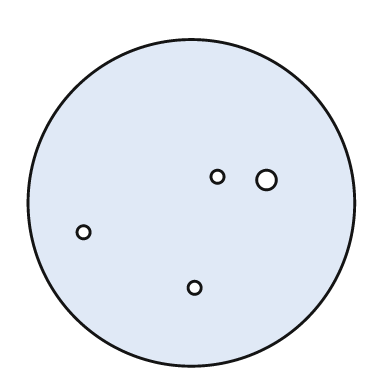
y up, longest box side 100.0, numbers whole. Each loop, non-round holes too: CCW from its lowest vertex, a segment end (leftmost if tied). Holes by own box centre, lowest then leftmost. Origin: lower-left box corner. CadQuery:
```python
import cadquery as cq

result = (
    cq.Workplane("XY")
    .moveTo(50.0, 50.0)
    .circle(50.0)
    .moveTo(51.0, 24.0)
    .circle(2.0)
    .moveTo(17.0, 41.0)
    .circle(2.0)
    .moveTo(73.0, 57.0)
    .circle(3.0)
    .moveTo(58.0, 58.0)
    .circle(2.0)
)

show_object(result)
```